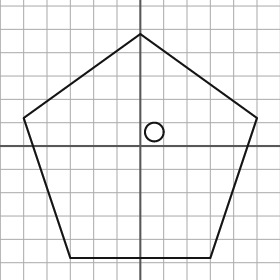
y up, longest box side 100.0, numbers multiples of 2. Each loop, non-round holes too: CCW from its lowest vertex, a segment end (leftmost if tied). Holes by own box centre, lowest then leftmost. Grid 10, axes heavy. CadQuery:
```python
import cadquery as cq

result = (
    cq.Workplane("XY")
    .moveTo(-30.0, -48.0)
    .lineTo(30.0, -48.0)
    .lineTo(50.0, 12.0)
    .lineTo(0.0, 48.0)
    .lineTo(-50.0, 12.0)
    .close()
    .moveTo(6.0, 6.0)
    .circle(4.0)
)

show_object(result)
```